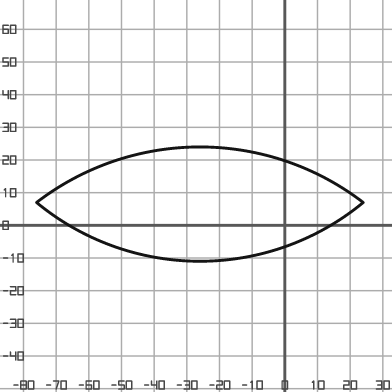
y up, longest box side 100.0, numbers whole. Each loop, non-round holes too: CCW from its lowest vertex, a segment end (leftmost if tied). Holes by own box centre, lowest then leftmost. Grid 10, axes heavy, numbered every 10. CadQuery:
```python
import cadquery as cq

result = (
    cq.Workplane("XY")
    .moveTo(-76.0, 7.0)
    .threePointArc((-26.0, -11.0), (24.0, 7.0))
    .threePointArc((-26.0, 24.0), (-76.0, 7.0))
    .close()
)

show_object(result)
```